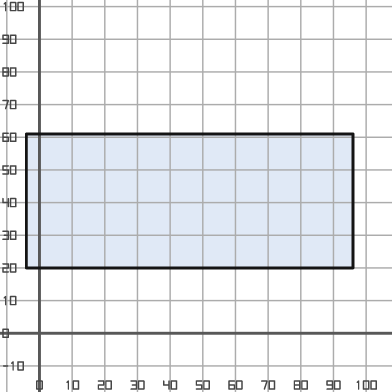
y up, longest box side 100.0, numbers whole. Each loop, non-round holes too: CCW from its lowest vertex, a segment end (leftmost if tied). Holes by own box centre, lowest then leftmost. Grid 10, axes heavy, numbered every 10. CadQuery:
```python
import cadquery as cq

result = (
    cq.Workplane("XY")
    .moveTo(-4.0, 20.0)
    .lineTo(96.0, 20.0)
    .lineTo(96.0, 61.0)
    .lineTo(-4.0, 61.0)
    .close()
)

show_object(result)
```